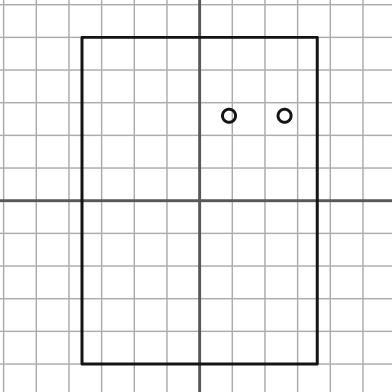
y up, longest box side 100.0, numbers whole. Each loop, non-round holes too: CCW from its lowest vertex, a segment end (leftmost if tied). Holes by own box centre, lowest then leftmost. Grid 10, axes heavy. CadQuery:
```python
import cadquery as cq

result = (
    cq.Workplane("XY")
    .moveTo(-36.0, -50.0)
    .lineTo(36.0, -50.0)
    .lineTo(36.0, 50.0)
    .lineTo(-36.0, 50.0)
    .close()
    .moveTo(9.0, 26.0)
    .circle(2.0)
    .moveTo(26.0, 26.0)
    .circle(2.0)
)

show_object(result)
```